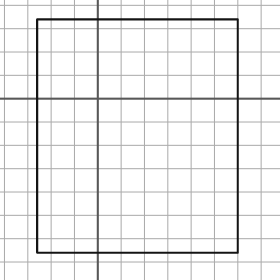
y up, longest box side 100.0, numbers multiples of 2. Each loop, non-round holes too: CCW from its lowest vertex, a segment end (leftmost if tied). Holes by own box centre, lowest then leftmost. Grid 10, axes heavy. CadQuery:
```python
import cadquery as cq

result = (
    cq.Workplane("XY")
    .moveTo(-26.0, -66.0)
    .lineTo(60.0, -66.0)
    .lineTo(60.0, 34.0)
    .lineTo(-26.0, 34.0)
    .close()
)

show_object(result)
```